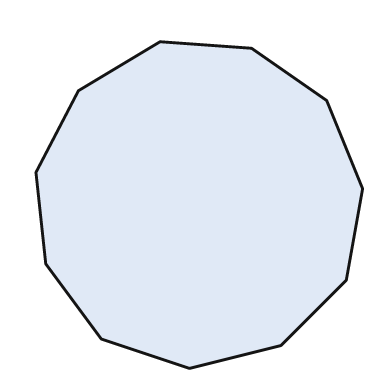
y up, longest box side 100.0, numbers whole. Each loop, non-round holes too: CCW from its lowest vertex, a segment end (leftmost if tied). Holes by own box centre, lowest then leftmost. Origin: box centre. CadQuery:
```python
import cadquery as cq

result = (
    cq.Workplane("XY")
    .moveTo(-3.0, -50.0)
    .lineTo(25.0, -43.0)
    .lineTo(45.0, -23.0)
    .lineTo(50.0, 5.0)
    .lineTo(39.0, 32.0)
    .lineTo(16.0, 48.0)
    .lineTo(-12.0, 50.0)
    .lineTo(-37.0, 35.0)
    .lineTo(-50.0, 10.0)
    .lineTo(-47.0, -18.0)
    .lineTo(-30.0, -41.0)
    .close()
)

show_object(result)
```